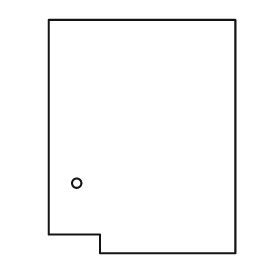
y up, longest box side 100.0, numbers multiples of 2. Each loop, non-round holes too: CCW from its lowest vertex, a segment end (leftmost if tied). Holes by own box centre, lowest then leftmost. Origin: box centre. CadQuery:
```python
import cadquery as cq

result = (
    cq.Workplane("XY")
    .moveTo(-18.0, -50.0)
    .lineTo(40.0, -50.0)
    .lineTo(40.0, 50.0)
    .lineTo(-40.0, 50.0)
    .lineTo(-40.0, -42.0)
    .lineTo(-18.0, -42.0)
    .close()
    .moveTo(-28.0, -20.0)
    .circle(2.0)
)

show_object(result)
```